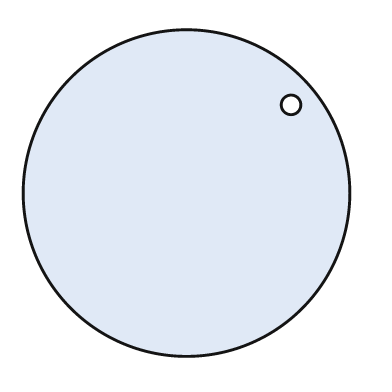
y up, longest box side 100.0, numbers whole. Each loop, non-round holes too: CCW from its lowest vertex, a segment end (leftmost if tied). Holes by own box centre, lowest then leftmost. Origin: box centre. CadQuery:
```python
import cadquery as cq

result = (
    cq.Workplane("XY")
    .moveTo(0.0, 0.0)
    .circle(50.0)
    .moveTo(32.0, 27.0)
    .circle(3.0)
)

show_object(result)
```